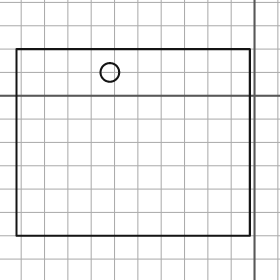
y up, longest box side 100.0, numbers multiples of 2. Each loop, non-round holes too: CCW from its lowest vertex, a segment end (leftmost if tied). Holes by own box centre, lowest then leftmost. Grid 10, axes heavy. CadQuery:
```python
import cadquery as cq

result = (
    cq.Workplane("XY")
    .moveTo(-102.0, -60.0)
    .lineTo(-2.0, -60.0)
    .lineTo(-2.0, 20.0)
    .lineTo(-102.0, 20.0)
    .close()
    .moveTo(-62.0, 10.0)
    .circle(4.0)
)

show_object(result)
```